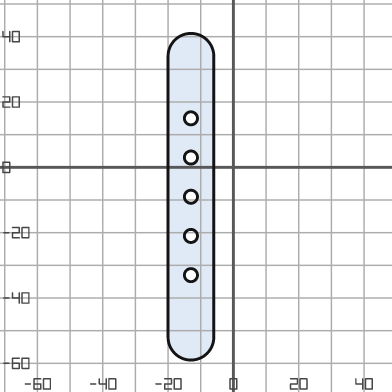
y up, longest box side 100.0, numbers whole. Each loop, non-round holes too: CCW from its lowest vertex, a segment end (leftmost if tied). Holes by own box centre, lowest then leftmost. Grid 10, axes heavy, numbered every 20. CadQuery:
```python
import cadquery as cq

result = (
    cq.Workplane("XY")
    .moveTo(-20.0, -52.0)
    .threePointArc((-13.0, -59.0), (-6.0, -52.0))
    .lineTo(-6.0, 34.0)
    .threePointArc((-13.0, 41.0), (-20.0, 34.0))
    .close()
    .moveTo(-13.0, -33.0)
    .circle(2.0)
    .moveTo(-13.0, -21.0)
    .circle(2.0)
    .moveTo(-13.0, -9.0)
    .circle(2.0)
    .moveTo(-13.0, 3.0)
    .circle(2.0)
    .moveTo(-13.0, 15.0)
    .circle(2.0)
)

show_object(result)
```